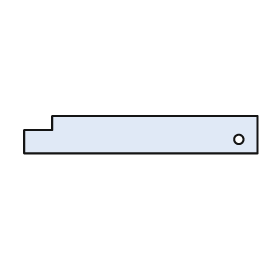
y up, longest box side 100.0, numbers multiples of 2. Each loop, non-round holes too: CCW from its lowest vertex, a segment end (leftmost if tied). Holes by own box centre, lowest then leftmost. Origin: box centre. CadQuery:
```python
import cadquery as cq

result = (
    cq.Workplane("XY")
    .moveTo(-50.0, -8.0)
    .lineTo(50.0, -8.0)
    .lineTo(50.0, 8.0)
    .lineTo(-38.0, 8.0)
    .lineTo(-38.0, 2.0)
    .lineTo(-50.0, 2.0)
    .close()
    .moveTo(42.0, -2.0)
    .circle(2.0)
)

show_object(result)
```